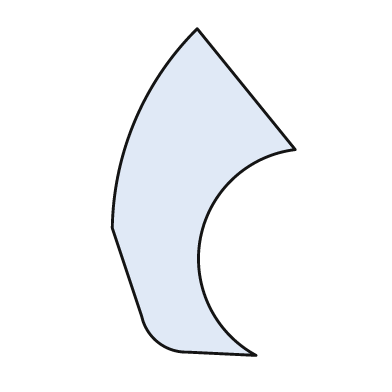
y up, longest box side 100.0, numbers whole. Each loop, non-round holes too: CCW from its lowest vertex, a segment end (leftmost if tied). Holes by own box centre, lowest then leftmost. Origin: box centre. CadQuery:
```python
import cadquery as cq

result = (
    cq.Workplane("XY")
    .moveTo(16.0, -50.0)
    .threePointArc((-1.0, -14.0), (28.0, 13.0))
    .lineTo(-2.0, 50.0)
    .threePointArc((-21.0, 22.0), (-28.0, -11.0))
    .lineTo(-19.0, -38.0)
    .threePointArc((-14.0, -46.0), (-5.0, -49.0))
    .close()
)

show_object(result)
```